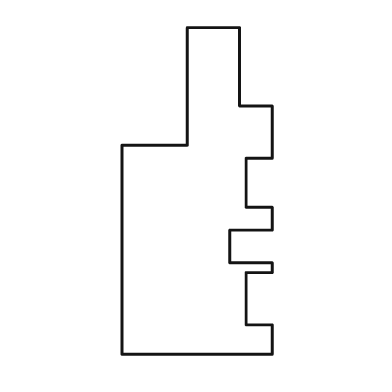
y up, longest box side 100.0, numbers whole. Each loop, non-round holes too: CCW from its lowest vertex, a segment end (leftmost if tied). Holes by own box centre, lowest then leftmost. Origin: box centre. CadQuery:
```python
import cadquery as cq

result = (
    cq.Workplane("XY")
    .moveTo(-23.0, -50.0)
    .lineTo(23.0, -50.0)
    .lineTo(23.0, -41.0)
    .lineTo(15.0, -41.0)
    .lineTo(15.0, -25.0)
    .lineTo(23.0, -25.0)
    .lineTo(23.0, -22.0)
    .lineTo(10.0, -22.0)
    .lineTo(10.0, -12.0)
    .lineTo(23.0, -12.0)
    .lineTo(23.0, -5.0)
    .lineTo(15.0, -5.0)
    .lineTo(15.0, 10.0)
    .lineTo(23.0, 10.0)
    .lineTo(23.0, 26.0)
    .lineTo(13.0, 26.0)
    .lineTo(13.0, 50.0)
    .lineTo(-3.0, 50.0)
    .lineTo(-3.0, 14.0)
    .lineTo(-23.0, 14.0)
    .close()
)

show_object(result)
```